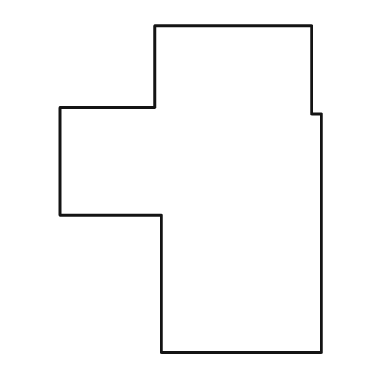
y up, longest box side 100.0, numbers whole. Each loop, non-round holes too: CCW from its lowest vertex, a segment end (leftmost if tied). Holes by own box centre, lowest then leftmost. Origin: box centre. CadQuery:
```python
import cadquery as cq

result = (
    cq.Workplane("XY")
    .moveTo(-9.0, -50.0)
    .lineTo(40.0, -50.0)
    .lineTo(40.0, 23.0)
    .lineTo(37.0, 23.0)
    .lineTo(37.0, 50.0)
    .lineTo(-11.0, 50.0)
    .lineTo(-11.0, 25.0)
    .lineTo(-40.0, 25.0)
    .lineTo(-40.0, -8.0)
    .lineTo(-9.0, -8.0)
    .close()
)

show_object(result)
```